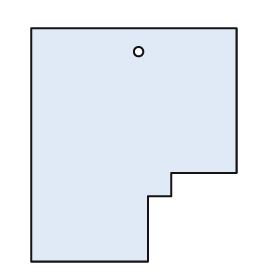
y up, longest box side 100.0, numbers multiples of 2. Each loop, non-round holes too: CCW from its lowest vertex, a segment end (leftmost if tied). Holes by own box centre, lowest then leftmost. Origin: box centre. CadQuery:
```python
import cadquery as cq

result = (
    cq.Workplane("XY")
    .moveTo(-44.0, -50.0)
    .lineTo(6.0, -50.0)
    .lineTo(6.0, -22.0)
    .lineTo(16.0, -22.0)
    .lineTo(16.0, -12.0)
    .lineTo(44.0, -12.0)
    .lineTo(44.0, 50.0)
    .lineTo(-44.0, 50.0)
    .close()
    .moveTo(2.0, 40.0)
    .circle(2.0)
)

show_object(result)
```